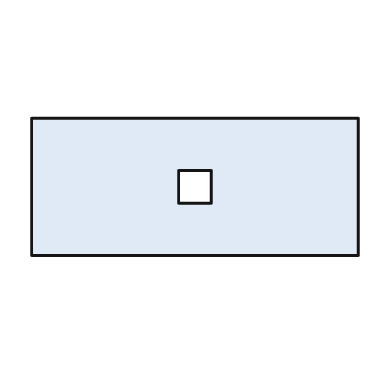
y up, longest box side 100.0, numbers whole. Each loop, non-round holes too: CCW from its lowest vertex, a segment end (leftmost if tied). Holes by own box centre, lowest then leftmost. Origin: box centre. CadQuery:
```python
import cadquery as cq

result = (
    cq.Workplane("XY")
    .moveTo(-50.0, -21.0)
    .lineTo(50.0, -21.0)
    .lineTo(50.0, 21.0)
    .lineTo(-50.0, 21.0)
    .close()
    .moveTo(-5.0, -5.0)
    .lineTo(5.0, -5.0)
    .lineTo(5.0, 5.0)
    .lineTo(-5.0, 5.0)
    .close()
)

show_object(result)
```